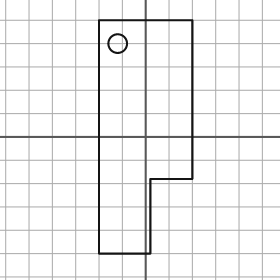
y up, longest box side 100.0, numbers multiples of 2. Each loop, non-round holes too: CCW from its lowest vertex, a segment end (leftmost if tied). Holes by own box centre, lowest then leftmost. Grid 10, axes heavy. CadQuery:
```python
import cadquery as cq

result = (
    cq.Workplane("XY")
    .moveTo(-20.0, -50.0)
    .lineTo(2.0, -50.0)
    .lineTo(2.0, -18.0)
    .lineTo(20.0, -18.0)
    .lineTo(20.0, 50.0)
    .lineTo(-20.0, 50.0)
    .close()
    .moveTo(-12.0, 40.0)
    .circle(4.0)
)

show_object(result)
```